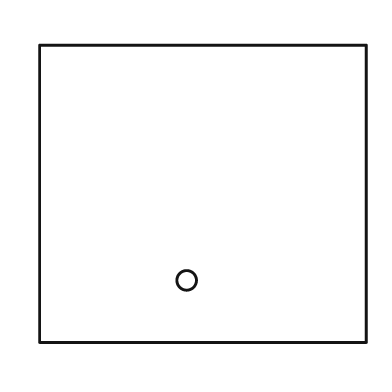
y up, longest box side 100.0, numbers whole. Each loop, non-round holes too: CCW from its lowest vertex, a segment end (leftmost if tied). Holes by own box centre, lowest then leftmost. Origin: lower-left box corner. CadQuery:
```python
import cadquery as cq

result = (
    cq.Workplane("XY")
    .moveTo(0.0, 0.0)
    .lineTo(100.0, 0.0)
    .lineTo(100.0, 91.0)
    .lineTo(0.0, 91.0)
    .close()
    .moveTo(45.0, 19.0)
    .circle(3.0)
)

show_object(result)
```